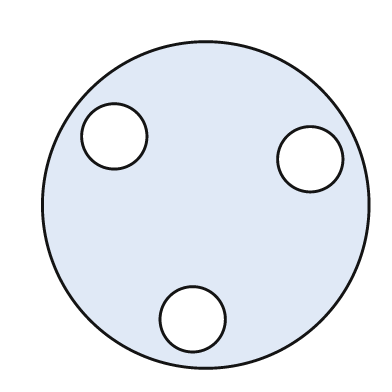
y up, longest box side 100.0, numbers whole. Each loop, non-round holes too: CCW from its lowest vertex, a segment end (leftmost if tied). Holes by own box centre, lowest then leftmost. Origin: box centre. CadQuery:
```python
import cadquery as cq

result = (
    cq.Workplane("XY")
    .moveTo(0.0, 0.0)
    .circle(50.0)
    .moveTo(-4.0, -35.0)
    .circle(10.0)
    .moveTo(32.0, 14.0)
    .circle(10.0)
    .moveTo(-28.0, 21.0)
    .circle(10.0)
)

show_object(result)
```